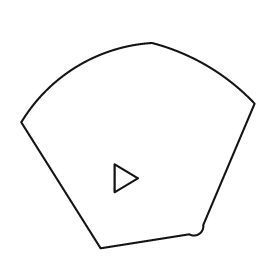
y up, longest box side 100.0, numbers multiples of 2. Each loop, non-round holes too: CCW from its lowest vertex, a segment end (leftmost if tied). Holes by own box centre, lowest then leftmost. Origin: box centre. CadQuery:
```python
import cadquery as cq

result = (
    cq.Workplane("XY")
    .moveTo(-16.0, -44.0)
    .lineTo(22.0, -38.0)
    .threePointArc((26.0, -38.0), (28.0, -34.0))
    .lineTo(50.0, 18.0)
    .threePointArc((30.0, 34.0), (6.0, 44.0))
    .threePointArc((-26.0, 34.0), (-50.0, 10.0))
    .close()
    .moveTo(-10.0, -20.0)
    .lineTo(0.0, -14.0)
    .lineTo(-10.0, -8.0)
    .close()
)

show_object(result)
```